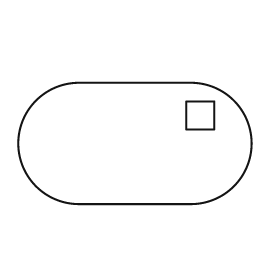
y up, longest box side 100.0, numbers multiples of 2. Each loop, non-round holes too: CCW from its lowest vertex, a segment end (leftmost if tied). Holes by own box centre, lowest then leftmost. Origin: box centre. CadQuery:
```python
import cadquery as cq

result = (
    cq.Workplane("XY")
    .moveTo(-24.0, -26.0)
    .lineTo(24.0, -26.0)
    .threePointArc((50.0, 0.0), (24.0, 26.0))
    .lineTo(-24.0, 26.0)
    .threePointArc((-50.0, 0.0), (-24.0, -26.0))
    .close()
    .moveTo(22.0, 6.0)
    .lineTo(34.0, 6.0)
    .lineTo(34.0, 18.0)
    .lineTo(22.0, 18.0)
    .close()
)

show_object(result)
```